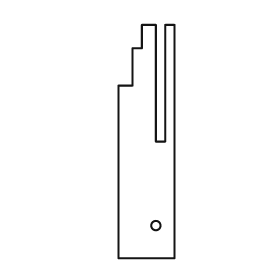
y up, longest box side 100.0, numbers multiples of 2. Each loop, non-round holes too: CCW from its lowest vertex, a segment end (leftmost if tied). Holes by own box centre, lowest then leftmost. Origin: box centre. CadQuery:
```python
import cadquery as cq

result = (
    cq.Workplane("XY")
    .moveTo(-12.0, -50.0)
    .lineTo(12.0, -50.0)
    .lineTo(12.0, 50.0)
    .lineTo(8.0, 50.0)
    .lineTo(8.0, 0.0)
    .lineTo(4.0, 0.0)
    .lineTo(4.0, 50.0)
    .lineTo(-2.0, 50.0)
    .lineTo(-2.0, 40.0)
    .lineTo(-6.0, 40.0)
    .lineTo(-6.0, 24.0)
    .lineTo(-12.0, 24.0)
    .close()
    .moveTo(4.0, -36.0)
    .circle(2.0)
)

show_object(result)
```